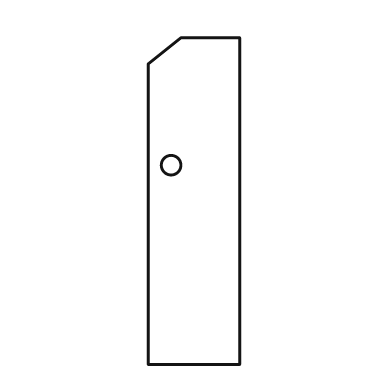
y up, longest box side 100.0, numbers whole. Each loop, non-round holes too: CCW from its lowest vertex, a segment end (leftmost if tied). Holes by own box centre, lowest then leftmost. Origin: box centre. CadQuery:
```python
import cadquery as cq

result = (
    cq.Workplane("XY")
    .moveTo(-14.0, -50.0)
    .lineTo(14.0, -50.0)
    .lineTo(14.0, 50.0)
    .lineTo(-4.0, 50.0)
    .lineTo(-14.0, 42.0)
    .close()
    .moveTo(-7.0, 11.0)
    .circle(3.0)
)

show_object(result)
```